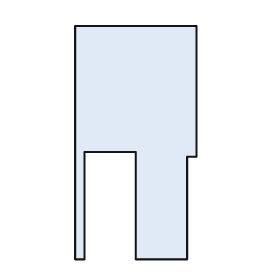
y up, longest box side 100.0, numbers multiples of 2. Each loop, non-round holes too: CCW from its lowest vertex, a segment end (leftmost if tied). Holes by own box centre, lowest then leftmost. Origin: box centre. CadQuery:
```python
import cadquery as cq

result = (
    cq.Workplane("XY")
    .moveTo(-26.0, -50.0)
    .lineTo(-22.0, -50.0)
    .lineTo(-22.0, -4.0)
    .lineTo(0.0, -4.0)
    .lineTo(0.0, -50.0)
    .lineTo(22.0, -50.0)
    .lineTo(22.0, -6.0)
    .lineTo(26.0, -6.0)
    .lineTo(26.0, 50.0)
    .lineTo(-26.0, 50.0)
    .close()
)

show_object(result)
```